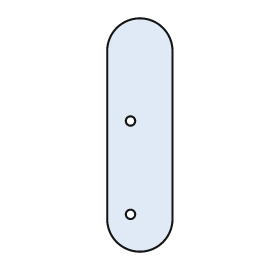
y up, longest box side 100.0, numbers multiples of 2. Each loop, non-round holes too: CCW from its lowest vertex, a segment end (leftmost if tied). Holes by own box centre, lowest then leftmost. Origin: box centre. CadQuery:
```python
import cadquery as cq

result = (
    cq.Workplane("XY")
    .moveTo(-14.0, -36.0)
    .threePointArc((0.0, -50.0), (14.0, -36.0))
    .lineTo(14.0, 36.0)
    .threePointArc((0.0, 50.0), (-14.0, 36.0))
    .close()
    .moveTo(-4.0, -34.0)
    .circle(2.0)
    .moveTo(-4.0, 6.0)
    .circle(2.0)
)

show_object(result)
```